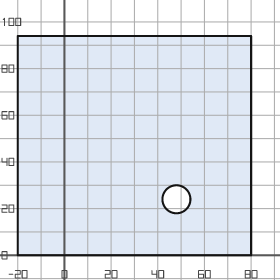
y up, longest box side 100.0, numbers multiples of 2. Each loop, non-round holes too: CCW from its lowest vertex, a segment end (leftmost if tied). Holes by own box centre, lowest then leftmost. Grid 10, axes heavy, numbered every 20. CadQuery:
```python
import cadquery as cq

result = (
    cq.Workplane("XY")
    .moveTo(-20.0, 0.0)
    .lineTo(80.0, 0.0)
    .lineTo(80.0, 94.0)
    .lineTo(-20.0, 94.0)
    .close()
    .moveTo(48.0, 24.0)
    .circle(6.0)
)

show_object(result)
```